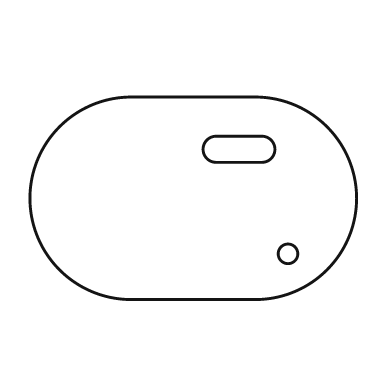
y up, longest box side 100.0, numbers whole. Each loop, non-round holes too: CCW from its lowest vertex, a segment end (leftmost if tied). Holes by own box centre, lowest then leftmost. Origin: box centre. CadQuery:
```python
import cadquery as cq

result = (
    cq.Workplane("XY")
    .moveTo(-19.0, -31.0)
    .lineTo(19.0, -31.0)
    .threePointArc((50.0, 0.0), (19.0, 31.0))
    .lineTo(-19.0, 31.0)
    .threePointArc((-50.0, 0.0), (-19.0, -31.0))
    .close()
    .moveTo(29.0, -17.0)
    .circle(3.0)
    .moveTo(7.0, 11.0)
    .lineTo(21.0, 11.0)
    .threePointArc((25.0, 15.0), (21.0, 19.0))
    .lineTo(7.0, 19.0)
    .threePointArc((3.0, 15.0), (7.0, 11.0))
    .close()
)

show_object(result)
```